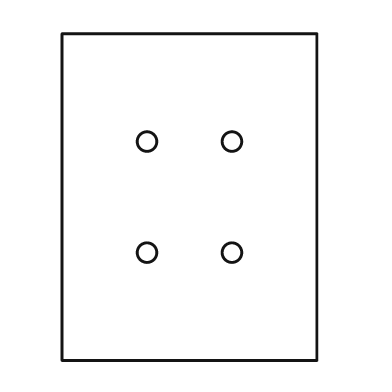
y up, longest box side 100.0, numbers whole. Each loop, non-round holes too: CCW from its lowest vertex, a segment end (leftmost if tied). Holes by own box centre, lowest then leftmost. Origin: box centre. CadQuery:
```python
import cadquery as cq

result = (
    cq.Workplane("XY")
    .moveTo(-39.0, -50.0)
    .lineTo(39.0, -50.0)
    .lineTo(39.0, 50.0)
    .lineTo(-39.0, 50.0)
    .close()
    .moveTo(-13.0, -17.0)
    .circle(3.0)
    .moveTo(13.0, -17.0)
    .circle(3.0)
    .moveTo(-13.0, 17.0)
    .circle(3.0)
    .moveTo(13.0, 17.0)
    .circle(3.0)
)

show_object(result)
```